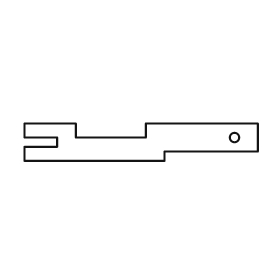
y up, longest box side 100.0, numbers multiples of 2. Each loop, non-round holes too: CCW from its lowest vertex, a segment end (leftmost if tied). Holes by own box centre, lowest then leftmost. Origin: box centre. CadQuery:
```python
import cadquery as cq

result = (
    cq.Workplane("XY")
    .moveTo(-50.0, -8.0)
    .lineTo(10.0, -8.0)
    .lineTo(10.0, -4.0)
    .lineTo(50.0, -4.0)
    .lineTo(50.0, 8.0)
    .lineTo(2.0, 8.0)
    .lineTo(2.0, 2.0)
    .lineTo(-28.0, 2.0)
    .lineTo(-28.0, 8.0)
    .lineTo(-50.0, 8.0)
    .lineTo(-50.0, 2.0)
    .lineTo(-36.0, 2.0)
    .lineTo(-36.0, -2.0)
    .lineTo(-50.0, -2.0)
    .close()
    .moveTo(40.0, 2.0)
    .circle(2.0)
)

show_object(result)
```